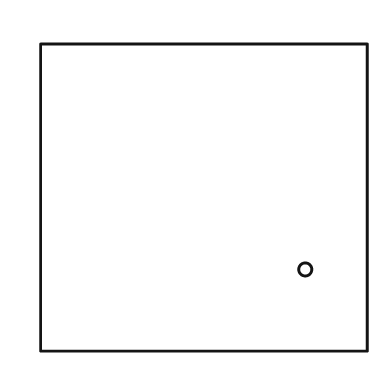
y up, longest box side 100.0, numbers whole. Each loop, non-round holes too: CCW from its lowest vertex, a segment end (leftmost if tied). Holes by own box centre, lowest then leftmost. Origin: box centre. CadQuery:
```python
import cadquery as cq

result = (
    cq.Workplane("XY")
    .moveTo(-50.0, -47.0)
    .lineTo(50.0, -47.0)
    .lineTo(50.0, 47.0)
    .lineTo(-50.0, 47.0)
    .close()
    .moveTo(31.0, -22.0)
    .circle(2.0)
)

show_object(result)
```